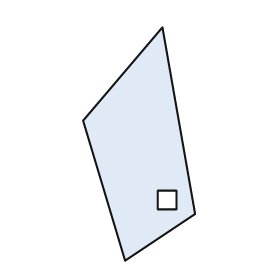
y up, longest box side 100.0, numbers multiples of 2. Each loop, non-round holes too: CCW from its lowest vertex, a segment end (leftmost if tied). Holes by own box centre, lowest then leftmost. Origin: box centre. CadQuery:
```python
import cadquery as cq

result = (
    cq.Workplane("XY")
    .moveTo(-6.0, -50.0)
    .lineTo(24.0, -30.0)
    .lineTo(10.0, 50.0)
    .lineTo(-24.0, 10.0)
    .close()
    .moveTo(8.0, -28.0)
    .lineTo(16.0, -28.0)
    .lineTo(16.0, -20.0)
    .lineTo(8.0, -20.0)
    .close()
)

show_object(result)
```